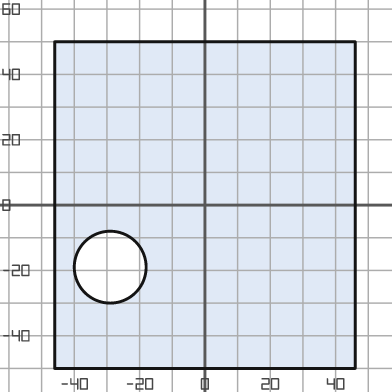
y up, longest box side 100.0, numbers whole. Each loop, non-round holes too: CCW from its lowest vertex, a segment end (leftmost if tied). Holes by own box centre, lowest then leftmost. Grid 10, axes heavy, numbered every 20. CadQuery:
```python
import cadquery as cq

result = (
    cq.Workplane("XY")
    .moveTo(-46.0, -50.0)
    .lineTo(46.0, -50.0)
    .lineTo(46.0, 50.0)
    .lineTo(-46.0, 50.0)
    .close()
    .moveTo(-29.0, -19.0)
    .circle(11.0)
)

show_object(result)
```